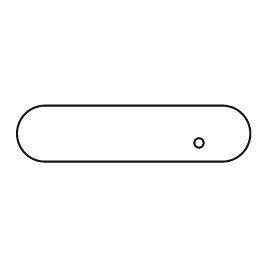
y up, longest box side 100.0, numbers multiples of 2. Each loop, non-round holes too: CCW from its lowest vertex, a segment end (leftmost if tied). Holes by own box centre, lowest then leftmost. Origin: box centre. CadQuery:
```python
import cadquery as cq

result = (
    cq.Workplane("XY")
    .moveTo(-38.0, -12.0)
    .lineTo(38.0, -12.0)
    .threePointArc((50.0, 0.0), (38.0, 12.0))
    .lineTo(-38.0, 12.0)
    .threePointArc((-50.0, 0.0), (-38.0, -12.0))
    .close()
    .moveTo(28.0, -4.0)
    .circle(2.0)
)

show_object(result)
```